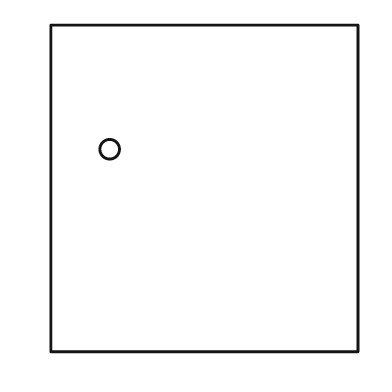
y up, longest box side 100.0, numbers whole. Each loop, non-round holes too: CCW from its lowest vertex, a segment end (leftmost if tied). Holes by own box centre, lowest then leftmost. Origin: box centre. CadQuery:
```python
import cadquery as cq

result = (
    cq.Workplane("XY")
    .moveTo(-47.0, -50.0)
    .lineTo(47.0, -50.0)
    .lineTo(47.0, 50.0)
    .lineTo(-47.0, 50.0)
    .close()
    .moveTo(-29.0, 12.0)
    .circle(3.0)
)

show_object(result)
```